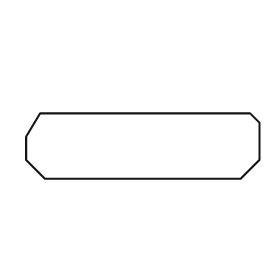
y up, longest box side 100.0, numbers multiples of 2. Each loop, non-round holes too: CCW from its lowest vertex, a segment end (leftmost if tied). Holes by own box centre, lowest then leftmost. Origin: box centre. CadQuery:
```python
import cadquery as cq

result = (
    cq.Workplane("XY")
    .moveTo(-42.0, -14.0)
    .lineTo(42.0, -14.0)
    .lineTo(50.0, -6.0)
    .lineTo(50.0, 10.0)
    .lineTo(46.0, 14.0)
    .lineTo(-44.0, 14.0)
    .lineTo(-50.0, 4.0)
    .lineTo(-50.0, -6.0)
    .close()
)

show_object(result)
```